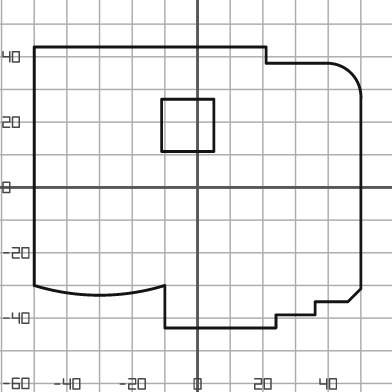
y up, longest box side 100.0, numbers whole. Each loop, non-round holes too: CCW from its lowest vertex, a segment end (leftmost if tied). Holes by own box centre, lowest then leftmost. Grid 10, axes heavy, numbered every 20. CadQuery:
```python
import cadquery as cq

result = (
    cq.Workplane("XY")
    .moveTo(-10.0, -43.0)
    .lineTo(24.0, -43.0)
    .lineTo(24.0, -39.0)
    .lineTo(36.0, -39.0)
    .lineTo(36.0, -35.0)
    .lineTo(46.0, -35.0)
    .lineTo(50.0, -31.0)
    .lineTo(50.0, 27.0)
    .threePointArc((47.0, 35.0), (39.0, 38.0))
    .lineTo(21.0, 38.0)
    .lineTo(21.0, 43.0)
    .lineTo(-50.0, 43.0)
    .lineTo(-50.0, -30.0)
    .threePointArc((-30.0, -33.0), (-10.0, -30.0))
    .close()
    .moveTo(-11.0, 11.0)
    .lineTo(5.0, 11.0)
    .lineTo(5.0, 27.0)
    .lineTo(-11.0, 27.0)
    .close()
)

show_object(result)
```